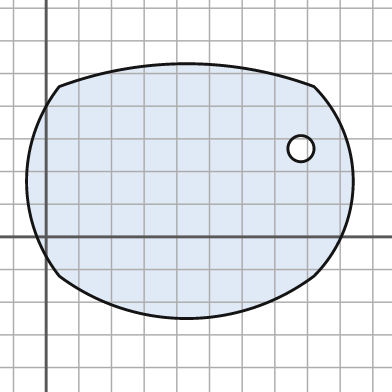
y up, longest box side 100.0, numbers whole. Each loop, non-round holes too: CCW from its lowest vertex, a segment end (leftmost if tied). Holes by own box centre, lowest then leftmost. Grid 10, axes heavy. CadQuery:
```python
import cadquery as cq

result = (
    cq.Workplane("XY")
    .moveTo(4.0, -12.0)
    .threePointArc((43.0, -25.0), (82.0, -12.0))
    .threePointArc((94.0, 17.0), (82.0, 46.0))
    .threePointArc((43.0, 53.0), (4.0, 46.0))
    .threePointArc((-6.0, 17.0), (4.0, -12.0))
    .close()
    .moveTo(78.0, 27.0)
    .circle(4.0)
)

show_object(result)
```